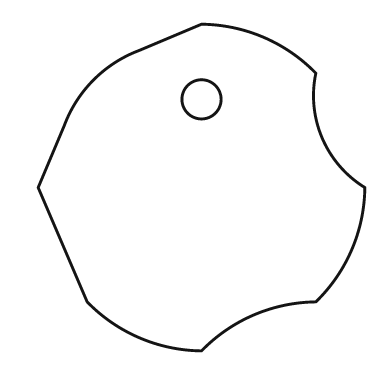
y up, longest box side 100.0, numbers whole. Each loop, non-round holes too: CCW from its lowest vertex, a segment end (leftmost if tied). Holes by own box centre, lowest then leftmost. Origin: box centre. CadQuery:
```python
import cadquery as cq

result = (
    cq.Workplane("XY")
    .moveTo(0.0, -50.0)
    .threePointArc((16.0, -39.0), (35.0, -35.0))
    .threePointArc((46.0, -19.0), (50.0, 0.0))
    .threePointArc((37.0, 15.0), (35.0, 35.0))
    .threePointArc((19.0, 46.0), (0.0, 50.0))
    .lineTo(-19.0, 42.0)
    .threePointArc((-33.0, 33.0), (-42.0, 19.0))
    .lineTo(-50.0, 0.0)
    .lineTo(-35.0, -35.0)
    .threePointArc((-19.0, -46.0), (0.0, -50.0))
    .close()
    .moveTo(0.0, 27.0)
    .circle(6.0)
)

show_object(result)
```